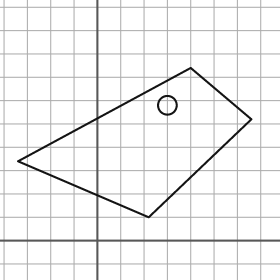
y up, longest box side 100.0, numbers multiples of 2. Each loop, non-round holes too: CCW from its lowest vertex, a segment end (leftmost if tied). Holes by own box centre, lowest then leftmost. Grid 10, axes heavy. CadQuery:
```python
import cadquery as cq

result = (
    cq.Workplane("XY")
    .moveTo(22.0, 10.0)
    .lineTo(66.0, 52.0)
    .lineTo(40.0, 74.0)
    .lineTo(-34.0, 34.0)
    .close()
    .moveTo(30.0, 58.0)
    .circle(4.0)
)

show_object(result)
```